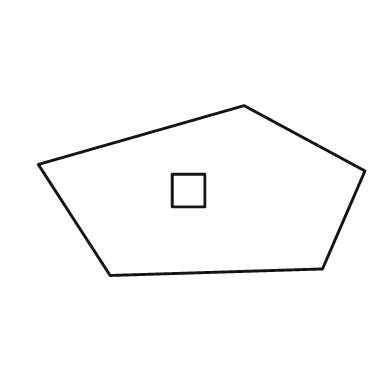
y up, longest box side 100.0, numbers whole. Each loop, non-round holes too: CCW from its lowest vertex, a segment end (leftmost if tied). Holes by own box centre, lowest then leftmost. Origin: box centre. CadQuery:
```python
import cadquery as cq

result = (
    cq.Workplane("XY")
    .moveTo(-28.0, -26.0)
    .lineTo(37.0, -24.0)
    .lineTo(50.0, 6.0)
    .lineTo(13.0, 26.0)
    .lineTo(-50.0, 8.0)
    .close()
    .moveTo(-9.0, -5.0)
    .lineTo(1.0, -5.0)
    .lineTo(1.0, 5.0)
    .lineTo(-9.0, 5.0)
    .close()
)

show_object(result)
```